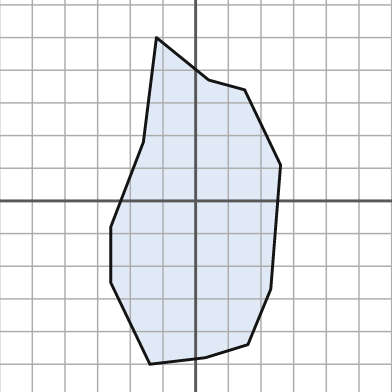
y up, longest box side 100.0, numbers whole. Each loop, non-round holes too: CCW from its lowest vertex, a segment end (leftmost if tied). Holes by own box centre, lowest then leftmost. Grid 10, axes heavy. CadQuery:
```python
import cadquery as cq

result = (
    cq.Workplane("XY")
    .moveTo(-14.0, -50.0)
    .lineTo(3.0, -48.0)
    .lineTo(16.0, -44.0)
    .lineTo(23.0, -27.0)
    .lineTo(26.0, 11.0)
    .lineTo(15.0, 34.0)
    .lineTo(4.0, 37.0)
    .lineTo(-12.0, 50.0)
    .lineTo(-16.0, 18.0)
    .lineTo(-26.0, -8.0)
    .lineTo(-26.0, -25.0)
    .close()
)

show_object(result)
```